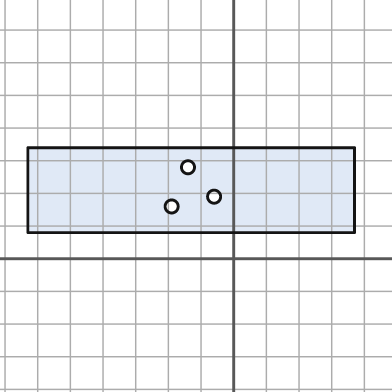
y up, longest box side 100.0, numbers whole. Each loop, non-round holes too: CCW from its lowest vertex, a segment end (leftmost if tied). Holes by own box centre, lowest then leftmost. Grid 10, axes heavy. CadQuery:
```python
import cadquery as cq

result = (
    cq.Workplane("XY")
    .moveTo(-63.0, 8.0)
    .lineTo(37.0, 8.0)
    .lineTo(37.0, 34.0)
    .lineTo(-63.0, 34.0)
    .close()
    .moveTo(-19.0, 16.0)
    .circle(2.0)
    .moveTo(-6.0, 19.0)
    .circle(2.0)
    .moveTo(-14.0, 28.0)
    .circle(2.0)
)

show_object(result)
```